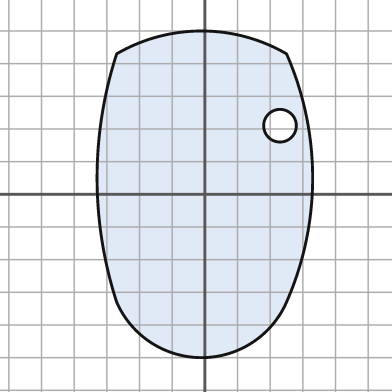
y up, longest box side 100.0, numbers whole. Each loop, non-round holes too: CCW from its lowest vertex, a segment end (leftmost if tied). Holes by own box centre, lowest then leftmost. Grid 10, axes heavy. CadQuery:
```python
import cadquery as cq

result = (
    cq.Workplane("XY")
    .moveTo(-27.0, -33.0)
    .threePointArc((-1.0, -50.0), (25.0, -33.0))
    .threePointArc((33.0, 5.0), (25.0, 43.0))
    .threePointArc((-1.0, 50.0), (-27.0, 43.0))
    .threePointArc((-33.0, 5.0), (-27.0, -33.0))
    .close()
    .moveTo(23.0, 21.0)
    .circle(5.0)
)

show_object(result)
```